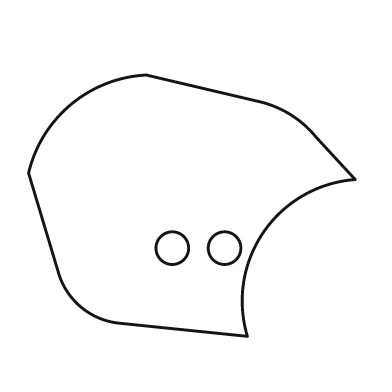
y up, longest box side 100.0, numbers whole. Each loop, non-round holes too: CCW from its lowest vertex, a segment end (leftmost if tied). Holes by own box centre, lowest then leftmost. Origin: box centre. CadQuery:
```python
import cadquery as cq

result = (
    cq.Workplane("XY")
    .moveTo(17.0, -40.0)
    .threePointArc((22.0, -8.0), (50.0, 8.0))
    .lineTo(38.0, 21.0)
    .threePointArc((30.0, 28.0), (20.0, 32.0))
    .lineTo(-14.0, 40.0)
    .threePointArc((-37.0, 31.0), (-50.0, 10.0))
    .lineTo(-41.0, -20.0)
    .threePointArc((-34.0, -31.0), (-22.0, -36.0))
    .close()
    .moveTo(-6.0, -13.0)
    .circle(5.0)
    .moveTo(10.0, -13.0)
    .circle(5.0)
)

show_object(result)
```